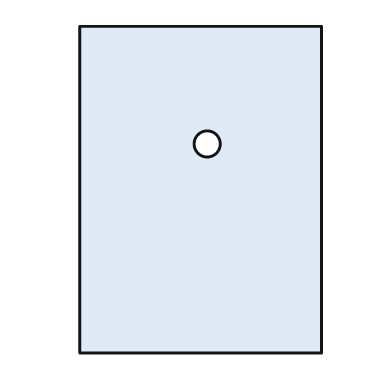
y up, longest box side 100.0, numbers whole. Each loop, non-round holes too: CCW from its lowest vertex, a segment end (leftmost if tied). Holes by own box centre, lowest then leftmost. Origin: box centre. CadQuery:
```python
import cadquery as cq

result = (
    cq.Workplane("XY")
    .moveTo(-37.0, -50.0)
    .lineTo(37.0, -50.0)
    .lineTo(37.0, 50.0)
    .lineTo(-37.0, 50.0)
    .close()
    .moveTo(2.0, 14.0)
    .circle(4.0)
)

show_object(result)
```